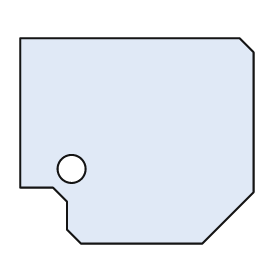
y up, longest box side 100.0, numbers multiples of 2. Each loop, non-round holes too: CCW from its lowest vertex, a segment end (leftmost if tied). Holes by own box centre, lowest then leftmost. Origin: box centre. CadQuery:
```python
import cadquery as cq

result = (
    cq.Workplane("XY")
    .moveTo(-24.0, -44.0)
    .lineTo(28.0, -44.0)
    .lineTo(50.0, -22.0)
    .lineTo(50.0, 38.0)
    .lineTo(44.0, 44.0)
    .lineTo(-50.0, 44.0)
    .lineTo(-50.0, -20.0)
    .lineTo(-36.0, -20.0)
    .lineTo(-30.0, -26.0)
    .lineTo(-30.0, -38.0)
    .close()
    .moveTo(-28.0, -12.0)
    .circle(6.0)
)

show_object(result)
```